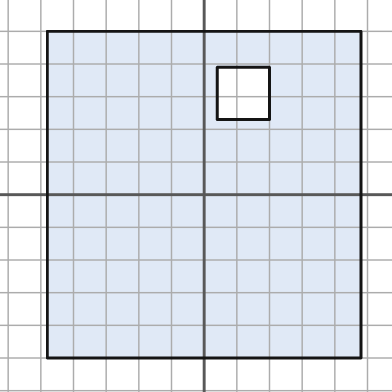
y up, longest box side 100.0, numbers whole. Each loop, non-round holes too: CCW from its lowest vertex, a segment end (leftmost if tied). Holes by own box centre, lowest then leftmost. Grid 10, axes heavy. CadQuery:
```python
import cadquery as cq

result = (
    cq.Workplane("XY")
    .moveTo(-48.0, -50.0)
    .lineTo(48.0, -50.0)
    .lineTo(48.0, 50.0)
    .lineTo(-48.0, 50.0)
    .close()
    .moveTo(4.0, 23.0)
    .lineTo(20.0, 23.0)
    .lineTo(20.0, 39.0)
    .lineTo(4.0, 39.0)
    .close()
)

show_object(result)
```